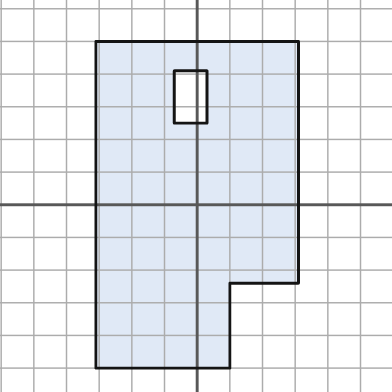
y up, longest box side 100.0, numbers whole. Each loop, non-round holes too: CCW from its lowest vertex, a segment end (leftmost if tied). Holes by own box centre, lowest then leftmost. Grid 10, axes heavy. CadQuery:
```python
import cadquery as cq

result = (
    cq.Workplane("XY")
    .moveTo(-31.0, -50.0)
    .lineTo(10.0, -50.0)
    .lineTo(10.0, -24.0)
    .lineTo(31.0, -24.0)
    .lineTo(31.0, 50.0)
    .lineTo(-31.0, 50.0)
    .close()
    .moveTo(-7.0, 25.0)
    .lineTo(3.0, 25.0)
    .lineTo(3.0, 41.0)
    .lineTo(-7.0, 41.0)
    .close()
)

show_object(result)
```